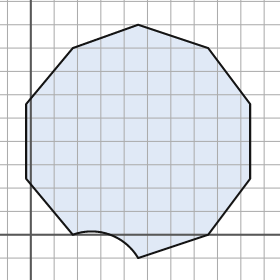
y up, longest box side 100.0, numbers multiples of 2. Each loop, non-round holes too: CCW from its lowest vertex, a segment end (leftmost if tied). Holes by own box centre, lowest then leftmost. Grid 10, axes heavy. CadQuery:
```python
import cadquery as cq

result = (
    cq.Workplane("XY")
    .moveTo(46.0, -10.0)
    .lineTo(76.0, 0.0)
    .lineTo(94.0, 24.0)
    .lineTo(94.0, 56.0)
    .lineTo(76.0, 80.0)
    .lineTo(46.0, 90.0)
    .lineTo(18.0, 80.0)
    .lineTo(-2.0, 56.0)
    .lineTo(-2.0, 24.0)
    .lineTo(18.0, 0.0)
    .threePointArc((34.0, 0.0), (46.0, -10.0))
    .close()
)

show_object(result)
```